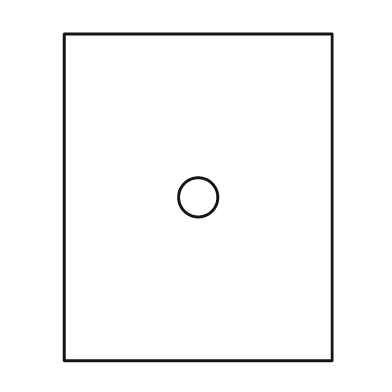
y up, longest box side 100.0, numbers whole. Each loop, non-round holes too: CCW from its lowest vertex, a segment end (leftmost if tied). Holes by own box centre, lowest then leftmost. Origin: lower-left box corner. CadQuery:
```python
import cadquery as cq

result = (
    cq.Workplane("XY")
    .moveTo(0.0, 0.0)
    .lineTo(82.0, 0.0)
    .lineTo(82.0, 100.0)
    .lineTo(0.0, 100.0)
    .close()
    .moveTo(41.0, 50.0)
    .circle(6.0)
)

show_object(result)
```